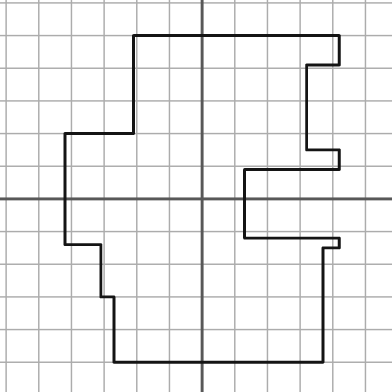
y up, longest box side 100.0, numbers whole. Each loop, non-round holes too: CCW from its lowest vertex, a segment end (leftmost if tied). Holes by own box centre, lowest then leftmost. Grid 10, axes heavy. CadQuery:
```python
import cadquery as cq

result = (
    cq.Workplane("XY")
    .moveTo(-27.0, -50.0)
    .lineTo(37.0, -50.0)
    .lineTo(37.0, -15.0)
    .lineTo(42.0, -15.0)
    .lineTo(42.0, -12.0)
    .lineTo(13.0, -12.0)
    .lineTo(13.0, 9.0)
    .lineTo(42.0, 9.0)
    .lineTo(42.0, 15.0)
    .lineTo(32.0, 15.0)
    .lineTo(32.0, 41.0)
    .lineTo(42.0, 41.0)
    .lineTo(42.0, 50.0)
    .lineTo(-21.0, 50.0)
    .lineTo(-21.0, 20.0)
    .lineTo(-42.0, 20.0)
    .lineTo(-42.0, -14.0)
    .lineTo(-31.0, -14.0)
    .lineTo(-31.0, -30.0)
    .lineTo(-27.0, -30.0)
    .close()
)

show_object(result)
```